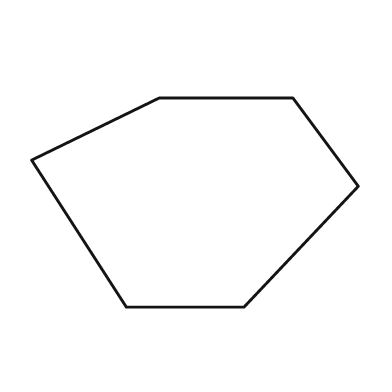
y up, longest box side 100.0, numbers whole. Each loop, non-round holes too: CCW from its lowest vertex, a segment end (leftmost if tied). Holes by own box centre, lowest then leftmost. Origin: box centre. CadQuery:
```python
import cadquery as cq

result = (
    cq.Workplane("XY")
    .moveTo(-21.0, -32.0)
    .lineTo(15.0, -32.0)
    .lineTo(50.0, 5.0)
    .lineTo(30.0, 32.0)
    .lineTo(-11.0, 32.0)
    .lineTo(-50.0, 13.0)
    .close()
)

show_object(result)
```